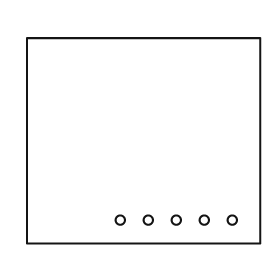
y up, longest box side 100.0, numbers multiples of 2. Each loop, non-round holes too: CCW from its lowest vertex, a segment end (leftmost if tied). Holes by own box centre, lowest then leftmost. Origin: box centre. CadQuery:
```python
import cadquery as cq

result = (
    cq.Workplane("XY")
    .moveTo(-50.0, -44.0)
    .lineTo(50.0, -44.0)
    .lineTo(50.0, 44.0)
    .lineTo(-50.0, 44.0)
    .close()
    .moveTo(-10.0, -34.0)
    .circle(2.0)
    .moveTo(2.0, -34.0)
    .circle(2.0)
    .moveTo(14.0, -34.0)
    .circle(2.0)
    .moveTo(26.0, -34.0)
    .circle(2.0)
    .moveTo(38.0, -34.0)
    .circle(2.0)
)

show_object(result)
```